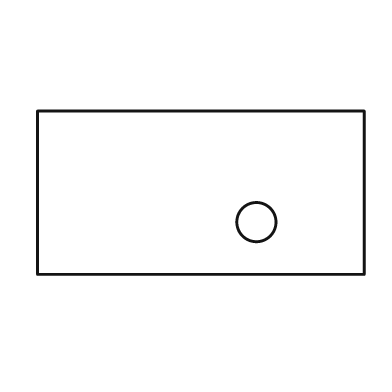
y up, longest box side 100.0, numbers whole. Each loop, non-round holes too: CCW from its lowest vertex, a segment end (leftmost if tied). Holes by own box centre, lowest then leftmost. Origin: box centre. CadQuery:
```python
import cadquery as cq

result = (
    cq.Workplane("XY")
    .moveTo(-50.0, -25.0)
    .lineTo(50.0, -25.0)
    .lineTo(50.0, 25.0)
    .lineTo(-50.0, 25.0)
    .close()
    .moveTo(17.0, -9.0)
    .circle(6.0)
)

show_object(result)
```